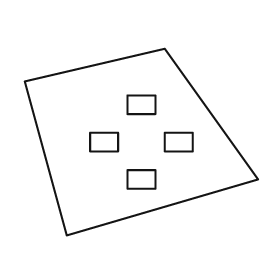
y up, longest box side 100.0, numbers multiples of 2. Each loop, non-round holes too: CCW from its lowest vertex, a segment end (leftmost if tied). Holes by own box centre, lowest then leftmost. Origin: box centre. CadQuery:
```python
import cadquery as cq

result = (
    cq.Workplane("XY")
    .moveTo(-32.0, -40.0)
    .lineTo(50.0, -16.0)
    .lineTo(10.0, 40.0)
    .lineTo(-50.0, 26.0)
    .close()
    .moveTo(-6.0, -20.0)
    .lineTo(6.0, -20.0)
    .lineTo(6.0, -12.0)
    .lineTo(-6.0, -12.0)
    .close()
    .moveTo(-22.0, -4.0)
    .lineTo(-10.0, -4.0)
    .lineTo(-10.0, 4.0)
    .lineTo(-22.0, 4.0)
    .close()
    .moveTo(10.0, -4.0)
    .lineTo(22.0, -4.0)
    .lineTo(22.0, 4.0)
    .lineTo(10.0, 4.0)
    .close()
    .moveTo(-6.0, 12.0)
    .lineTo(6.0, 12.0)
    .lineTo(6.0, 20.0)
    .lineTo(-6.0, 20.0)
    .close()
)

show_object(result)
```